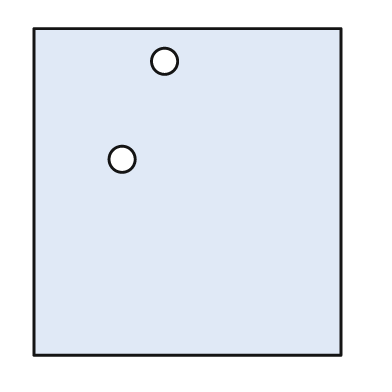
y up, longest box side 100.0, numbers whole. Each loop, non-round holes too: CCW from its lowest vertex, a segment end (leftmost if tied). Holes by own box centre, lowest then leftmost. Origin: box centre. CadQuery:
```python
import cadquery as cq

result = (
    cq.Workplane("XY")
    .moveTo(-47.0, -50.0)
    .lineTo(47.0, -50.0)
    .lineTo(47.0, 50.0)
    .lineTo(-47.0, 50.0)
    .close()
    .moveTo(-20.0, 10.0)
    .circle(4.0)
    .moveTo(-7.0, 40.0)
    .circle(4.0)
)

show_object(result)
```